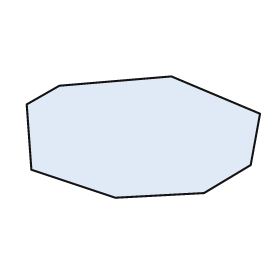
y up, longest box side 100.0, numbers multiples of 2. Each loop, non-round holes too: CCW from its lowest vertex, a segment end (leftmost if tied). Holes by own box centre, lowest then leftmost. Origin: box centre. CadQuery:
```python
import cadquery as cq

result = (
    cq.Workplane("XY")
    .moveTo(-12.0, -26.0)
    .lineTo(26.0, -24.0)
    .lineTo(46.0, -12.0)
    .lineTo(50.0, 10.0)
    .lineTo(12.0, 26.0)
    .lineTo(-36.0, 22.0)
    .lineTo(-50.0, 14.0)
    .lineTo(-48.0, -14.0)
    .close()
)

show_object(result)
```